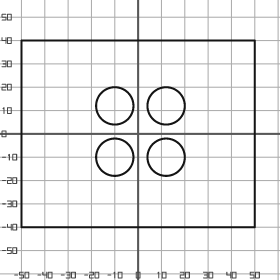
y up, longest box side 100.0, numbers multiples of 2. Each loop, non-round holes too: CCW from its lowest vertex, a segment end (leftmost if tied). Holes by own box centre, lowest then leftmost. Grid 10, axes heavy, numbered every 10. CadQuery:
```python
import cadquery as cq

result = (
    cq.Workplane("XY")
    .moveTo(-50.0, -40.0)
    .lineTo(50.0, -40.0)
    .lineTo(50.0, 40.0)
    .lineTo(-50.0, 40.0)
    .close()
    .moveTo(-10.0, -10.0)
    .circle(8.0)
    .moveTo(12.0, -10.0)
    .circle(8.0)
    .moveTo(-10.0, 12.0)
    .circle(8.0)
    .moveTo(12.0, 12.0)
    .circle(8.0)
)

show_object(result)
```